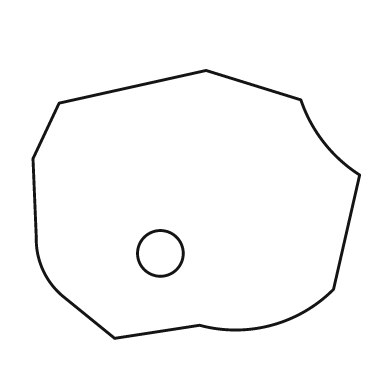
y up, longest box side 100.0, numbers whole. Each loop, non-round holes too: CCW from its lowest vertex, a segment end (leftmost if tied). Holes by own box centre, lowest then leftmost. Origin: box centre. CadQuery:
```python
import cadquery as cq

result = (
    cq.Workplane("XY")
    .moveTo(-25.0, -41.0)
    .lineTo(1.0, -37.0)
    .threePointArc((23.0, -37.0), (42.0, -26.0))
    .lineTo(50.0, 9.0)
    .threePointArc((39.0, 19.0), (32.0, 32.0))
    .lineTo(3.0, 41.0)
    .lineTo(-42.0, 31.0)
    .lineTo(-50.0, 14.0)
    .lineTo(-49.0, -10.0)
    .threePointArc((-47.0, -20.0), (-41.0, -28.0))
    .close()
    .moveTo(-11.0, -15.0)
    .circle(7.0)
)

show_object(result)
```